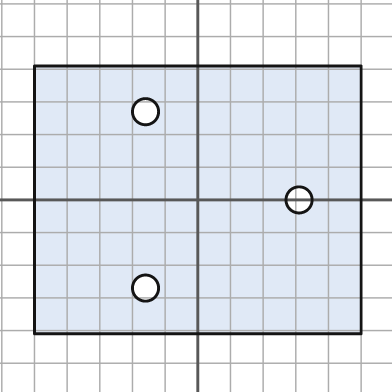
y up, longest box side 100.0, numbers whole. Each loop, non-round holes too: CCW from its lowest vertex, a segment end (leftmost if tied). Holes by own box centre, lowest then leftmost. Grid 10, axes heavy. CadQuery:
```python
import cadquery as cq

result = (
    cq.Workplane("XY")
    .moveTo(-50.0, -41.0)
    .lineTo(50.0, -41.0)
    .lineTo(50.0, 41.0)
    .lineTo(-50.0, 41.0)
    .close()
    .moveTo(-16.0, -27.0)
    .circle(4.0)
    .moveTo(31.0, 0.0)
    .circle(4.0)
    .moveTo(-16.0, 27.0)
    .circle(4.0)
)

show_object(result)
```